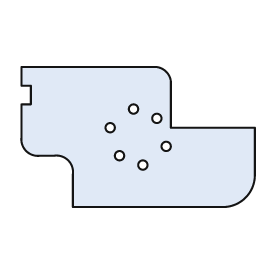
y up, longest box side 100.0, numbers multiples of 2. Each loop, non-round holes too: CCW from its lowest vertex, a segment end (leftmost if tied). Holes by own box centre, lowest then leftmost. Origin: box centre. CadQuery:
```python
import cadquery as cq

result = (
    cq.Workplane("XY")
    .moveTo(-28.0, -30.0)
    .lineTo(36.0, -30.0)
    .threePointArc((46.0, -26.0), (50.0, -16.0))
    .lineTo(50.0, 4.0)
    .lineTo(14.0, 4.0)
    .lineTo(14.0, 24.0)
    .threePointArc((12.0, 28.0), (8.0, 30.0))
    .lineTo(-50.0, 30.0)
    .lineTo(-50.0, 22.0)
    .lineTo(-46.0, 22.0)
    .lineTo(-46.0, 14.0)
    .lineTo(-50.0, 14.0)
    .lineTo(-50.0, 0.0)
    .threePointArc((-48.0, -6.0), (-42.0, -8.0))
    .lineTo(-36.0, -8.0)
    .threePointArc((-30.0, -10.0), (-28.0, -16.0))
    .close()
    .moveTo(2.0, -12.0)
    .circle(2.0)
    .moveTo(-8.0, -8.0)
    .circle(2.0)
    .moveTo(12.0, -4.0)
    .circle(2.0)
    .moveTo(-12.0, 4.0)
    .circle(2.0)
    .moveTo(8.0, 8.0)
    .circle(2.0)
    .moveTo(-2.0, 12.0)
    .circle(2.0)
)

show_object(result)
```